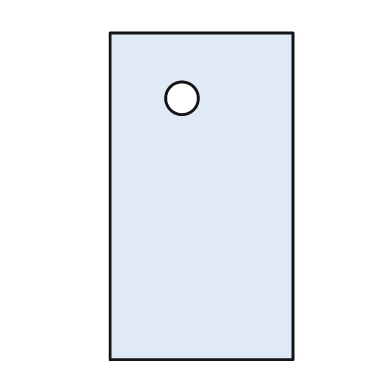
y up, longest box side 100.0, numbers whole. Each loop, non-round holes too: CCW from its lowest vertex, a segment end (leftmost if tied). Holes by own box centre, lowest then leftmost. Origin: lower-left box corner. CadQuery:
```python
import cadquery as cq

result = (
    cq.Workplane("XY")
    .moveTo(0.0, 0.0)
    .lineTo(56.0, 0.0)
    .lineTo(56.0, 100.0)
    .lineTo(0.0, 100.0)
    .close()
    .moveTo(22.0, 80.0)
    .circle(5.0)
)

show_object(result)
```